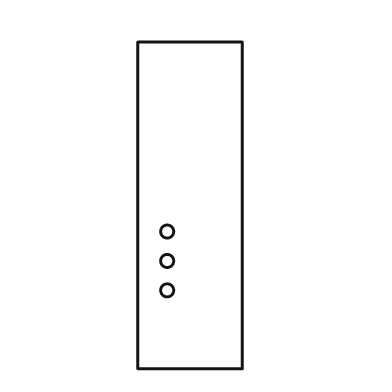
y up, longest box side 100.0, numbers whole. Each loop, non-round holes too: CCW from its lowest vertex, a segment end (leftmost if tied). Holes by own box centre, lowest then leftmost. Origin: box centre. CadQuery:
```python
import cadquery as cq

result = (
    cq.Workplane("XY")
    .moveTo(-16.0, -50.0)
    .lineTo(16.0, -50.0)
    .lineTo(16.0, 50.0)
    .lineTo(-16.0, 50.0)
    .close()
    .moveTo(-7.0, -26.0)
    .circle(2.0)
    .moveTo(-7.0, -17.0)
    .circle(2.0)
    .moveTo(-7.0, -8.0)
    .circle(2.0)
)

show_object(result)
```